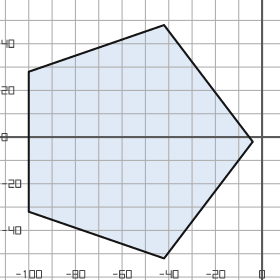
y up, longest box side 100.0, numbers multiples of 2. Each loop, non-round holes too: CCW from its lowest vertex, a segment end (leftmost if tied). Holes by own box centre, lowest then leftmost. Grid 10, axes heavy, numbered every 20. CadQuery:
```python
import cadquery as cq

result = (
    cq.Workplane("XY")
    .moveTo(-42.0, -52.0)
    .lineTo(-4.0, -2.0)
    .lineTo(-42.0, 48.0)
    .lineTo(-100.0, 28.0)
    .lineTo(-100.0, -32.0)
    .close()
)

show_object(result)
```